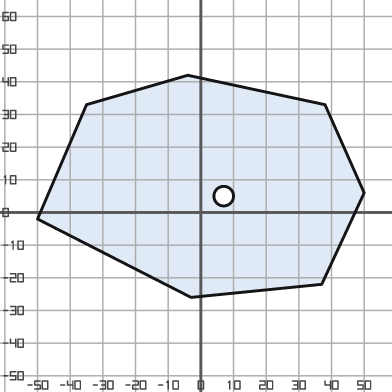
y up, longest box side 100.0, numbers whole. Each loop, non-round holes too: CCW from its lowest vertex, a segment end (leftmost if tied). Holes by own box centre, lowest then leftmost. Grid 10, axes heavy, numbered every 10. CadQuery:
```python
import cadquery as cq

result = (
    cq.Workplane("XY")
    .moveTo(-3.0, -26.0)
    .lineTo(37.0, -22.0)
    .lineTo(50.0, 6.0)
    .lineTo(38.0, 33.0)
    .lineTo(-4.0, 42.0)
    .lineTo(-35.0, 33.0)
    .lineTo(-50.0, -2.0)
    .close()
    .moveTo(7.0, 5.0)
    .circle(3.0)
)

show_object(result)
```